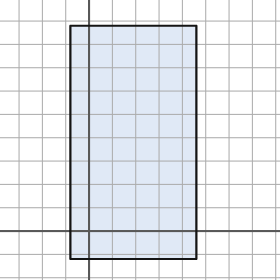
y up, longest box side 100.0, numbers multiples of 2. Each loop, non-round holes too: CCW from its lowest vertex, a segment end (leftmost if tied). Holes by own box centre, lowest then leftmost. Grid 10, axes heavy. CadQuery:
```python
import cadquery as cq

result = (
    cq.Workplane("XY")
    .moveTo(-8.0, -12.0)
    .lineTo(46.0, -12.0)
    .lineTo(46.0, 88.0)
    .lineTo(-8.0, 88.0)
    .close()
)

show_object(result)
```